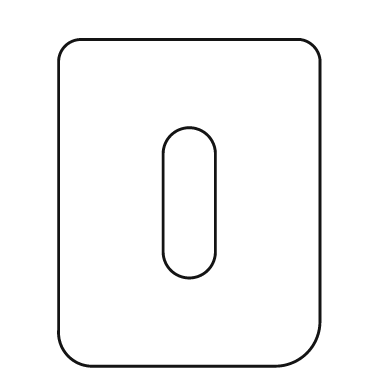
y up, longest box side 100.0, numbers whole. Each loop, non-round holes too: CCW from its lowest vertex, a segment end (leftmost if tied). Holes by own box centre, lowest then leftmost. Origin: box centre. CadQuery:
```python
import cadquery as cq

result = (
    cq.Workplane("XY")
    .moveTo(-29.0, -50.0)
    .lineTo(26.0, -50.0)
    .threePointArc((36.0, -46.0), (40.0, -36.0))
    .lineTo(40.0, 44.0)
    .threePointArc((38.0, 48.0), (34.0, 50.0))
    .lineTo(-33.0, 50.0)
    .threePointArc((-38.0, 48.0), (-40.0, 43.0))
    .lineTo(-40.0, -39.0)
    .threePointArc((-37.0, -47.0), (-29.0, -50.0))
    .close()
    .moveTo(-8.0, -15.0)
    .threePointArc((0.0, -23.0), (8.0, -15.0))
    .lineTo(8.0, 15.0)
    .threePointArc((0.0, 23.0), (-8.0, 15.0))
    .close()
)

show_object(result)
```